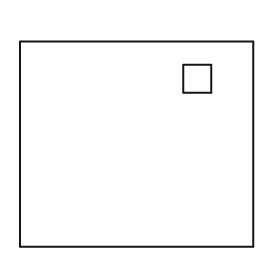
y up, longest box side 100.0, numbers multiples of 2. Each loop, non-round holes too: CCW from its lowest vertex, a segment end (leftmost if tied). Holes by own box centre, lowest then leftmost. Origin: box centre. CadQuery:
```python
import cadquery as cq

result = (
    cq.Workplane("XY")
    .moveTo(-50.0, -44.0)
    .lineTo(50.0, -44.0)
    .lineTo(50.0, 44.0)
    .lineTo(-50.0, 44.0)
    .close()
    .moveTo(20.0, 22.0)
    .lineTo(32.0, 22.0)
    .lineTo(32.0, 34.0)
    .lineTo(20.0, 34.0)
    .close()
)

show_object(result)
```